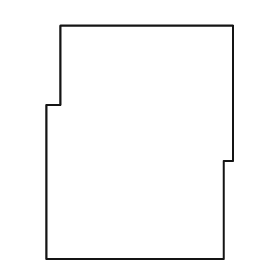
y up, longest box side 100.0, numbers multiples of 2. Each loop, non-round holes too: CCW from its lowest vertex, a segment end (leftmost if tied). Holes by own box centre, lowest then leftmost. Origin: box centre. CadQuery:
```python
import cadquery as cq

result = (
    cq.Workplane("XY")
    .moveTo(-40.0, -50.0)
    .lineTo(36.0, -50.0)
    .lineTo(36.0, -8.0)
    .lineTo(40.0, -8.0)
    .lineTo(40.0, 50.0)
    .lineTo(-34.0, 50.0)
    .lineTo(-34.0, 16.0)
    .lineTo(-40.0, 16.0)
    .close()
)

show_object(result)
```